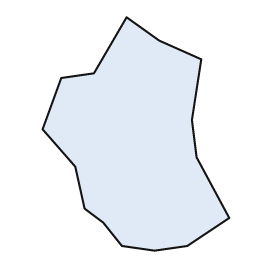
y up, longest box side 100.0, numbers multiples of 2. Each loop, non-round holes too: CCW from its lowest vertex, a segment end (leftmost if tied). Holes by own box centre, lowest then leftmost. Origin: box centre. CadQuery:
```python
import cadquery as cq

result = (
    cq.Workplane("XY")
    .moveTo(8.0, -50.0)
    .lineTo(22.0, -48.0)
    .lineTo(40.0, -36.0)
    .lineTo(26.0, -10.0)
    .lineTo(24.0, 6.0)
    .lineTo(28.0, 32.0)
    .lineTo(10.0, 40.0)
    .lineTo(-4.0, 50.0)
    .lineTo(-18.0, 26.0)
    .lineTo(-32.0, 24.0)
    .lineTo(-40.0, 2.0)
    .lineTo(-26.0, -14.0)
    .lineTo(-22.0, -32.0)
    .lineTo(-14.0, -38.0)
    .lineTo(-6.0, -48.0)
    .close()
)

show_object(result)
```